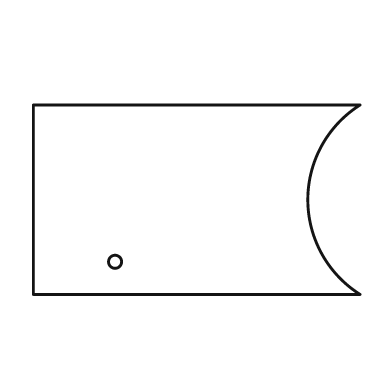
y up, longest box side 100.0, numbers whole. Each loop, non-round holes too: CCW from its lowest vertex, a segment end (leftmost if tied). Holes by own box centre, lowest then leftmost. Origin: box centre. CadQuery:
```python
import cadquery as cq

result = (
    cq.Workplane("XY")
    .moveTo(-50.0, -29.0)
    .lineTo(50.0, -29.0)
    .threePointArc((34.0, 0.0), (50.0, 29.0))
    .lineTo(-50.0, 29.0)
    .close()
    .moveTo(-25.0, -19.0)
    .circle(2.0)
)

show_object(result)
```